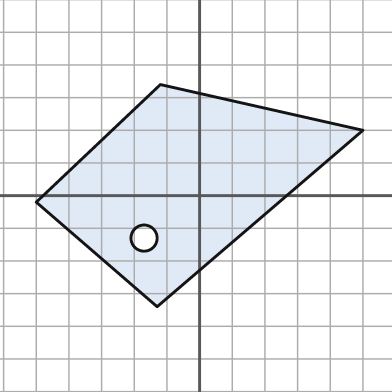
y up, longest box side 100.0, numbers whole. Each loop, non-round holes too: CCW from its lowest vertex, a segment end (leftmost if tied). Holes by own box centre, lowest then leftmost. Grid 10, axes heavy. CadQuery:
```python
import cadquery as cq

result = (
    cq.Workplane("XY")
    .moveTo(-13.0, -34.0)
    .lineTo(50.0, 20.0)
    .lineTo(-12.0, 34.0)
    .lineTo(-50.0, -2.0)
    .close()
    .moveTo(-17.0, -13.0)
    .circle(4.0)
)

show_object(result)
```